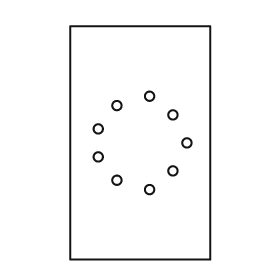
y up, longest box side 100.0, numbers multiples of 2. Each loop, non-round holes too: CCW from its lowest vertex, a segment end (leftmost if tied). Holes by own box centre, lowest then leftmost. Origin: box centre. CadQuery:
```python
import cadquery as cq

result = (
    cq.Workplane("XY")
    .moveTo(-30.0, -50.0)
    .lineTo(30.0, -50.0)
    .lineTo(30.0, 50.0)
    .lineTo(-30.0, 50.0)
    .close()
    .moveTo(4.0, -20.0)
    .circle(2.0)
    .moveTo(-10.0, -16.0)
    .circle(2.0)
    .moveTo(14.0, -12.0)
    .circle(2.0)
    .moveTo(-18.0, -6.0)
    .circle(2.0)
    .moveTo(20.0, 0.0)
    .circle(2.0)
    .moveTo(-18.0, 6.0)
    .circle(2.0)
    .moveTo(14.0, 12.0)
    .circle(2.0)
    .moveTo(-10.0, 16.0)
    .circle(2.0)
    .moveTo(4.0, 20.0)
    .circle(2.0)
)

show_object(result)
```